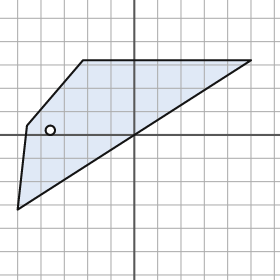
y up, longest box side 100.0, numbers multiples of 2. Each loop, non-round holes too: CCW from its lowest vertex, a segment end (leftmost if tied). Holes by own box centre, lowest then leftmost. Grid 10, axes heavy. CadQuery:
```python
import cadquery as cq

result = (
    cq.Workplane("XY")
    .moveTo(-50.0, -32.0)
    .lineTo(50.0, 32.0)
    .lineTo(-22.0, 32.0)
    .lineTo(-46.0, 4.0)
    .close()
    .moveTo(-36.0, 2.0)
    .circle(2.0)
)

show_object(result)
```